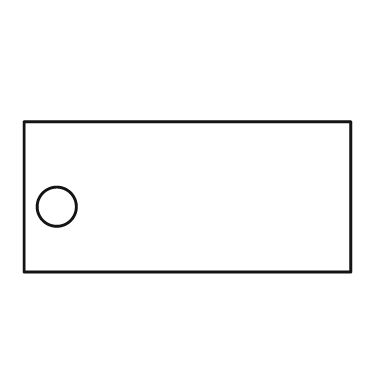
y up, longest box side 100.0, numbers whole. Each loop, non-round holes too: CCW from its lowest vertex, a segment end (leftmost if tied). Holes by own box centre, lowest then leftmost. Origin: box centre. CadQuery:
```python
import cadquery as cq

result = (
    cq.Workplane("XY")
    .moveTo(-50.0, -23.0)
    .lineTo(50.0, -23.0)
    .lineTo(50.0, 23.0)
    .lineTo(-50.0, 23.0)
    .close()
    .moveTo(-40.0, -3.0)
    .circle(6.0)
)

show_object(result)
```